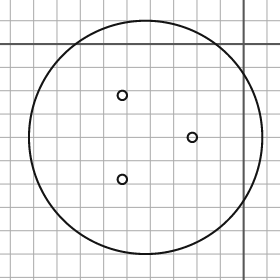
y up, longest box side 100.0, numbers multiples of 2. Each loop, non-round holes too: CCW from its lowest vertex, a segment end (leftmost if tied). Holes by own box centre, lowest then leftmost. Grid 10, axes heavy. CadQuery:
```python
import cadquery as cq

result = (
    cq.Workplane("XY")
    .moveTo(-42.0, -40.0)
    .circle(50.0)
    .moveTo(-52.0, -58.0)
    .circle(2.0)
    .moveTo(-22.0, -40.0)
    .circle(2.0)
    .moveTo(-52.0, -22.0)
    .circle(2.0)
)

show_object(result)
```